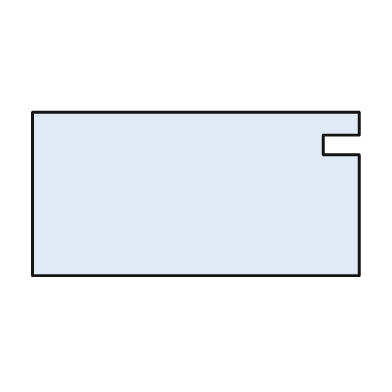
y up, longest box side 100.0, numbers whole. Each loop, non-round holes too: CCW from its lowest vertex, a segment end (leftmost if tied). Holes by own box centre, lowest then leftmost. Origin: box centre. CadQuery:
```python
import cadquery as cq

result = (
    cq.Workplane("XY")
    .moveTo(-50.0, -25.0)
    .lineTo(50.0, -25.0)
    .lineTo(50.0, 12.0)
    .lineTo(39.0, 12.0)
    .lineTo(39.0, 18.0)
    .lineTo(50.0, 18.0)
    .lineTo(50.0, 25.0)
    .lineTo(-50.0, 25.0)
    .close()
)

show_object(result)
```